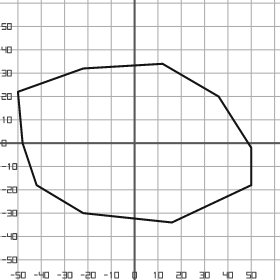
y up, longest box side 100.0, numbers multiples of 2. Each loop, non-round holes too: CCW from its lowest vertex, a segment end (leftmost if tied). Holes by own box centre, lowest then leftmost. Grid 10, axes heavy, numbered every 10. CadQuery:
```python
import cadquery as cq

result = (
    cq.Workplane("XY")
    .moveTo(16.0, -34.0)
    .lineTo(50.0, -18.0)
    .lineTo(50.0, -2.0)
    .lineTo(36.0, 20.0)
    .lineTo(12.0, 34.0)
    .lineTo(-22.0, 32.0)
    .lineTo(-50.0, 22.0)
    .lineTo(-48.0, 0.0)
    .lineTo(-42.0, -18.0)
    .lineTo(-22.0, -30.0)
    .close()
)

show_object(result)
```